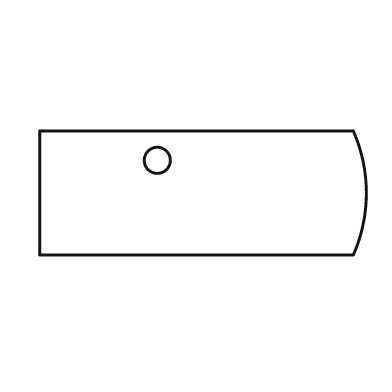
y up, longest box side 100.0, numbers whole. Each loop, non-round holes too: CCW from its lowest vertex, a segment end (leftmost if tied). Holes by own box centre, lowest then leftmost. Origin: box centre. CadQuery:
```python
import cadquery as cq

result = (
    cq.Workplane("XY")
    .moveTo(-50.0, -19.0)
    .lineTo(46.0, -19.0)
    .threePointArc((50.0, 0.0), (46.0, 19.0))
    .lineTo(-50.0, 19.0)
    .close()
    .moveTo(-14.0, 10.0)
    .circle(4.0)
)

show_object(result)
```